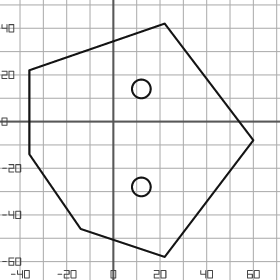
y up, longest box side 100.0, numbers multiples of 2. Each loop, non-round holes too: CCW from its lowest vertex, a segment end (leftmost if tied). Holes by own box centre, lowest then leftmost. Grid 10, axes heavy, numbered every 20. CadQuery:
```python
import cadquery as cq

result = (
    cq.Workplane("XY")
    .moveTo(22.0, -58.0)
    .lineTo(60.0, -8.0)
    .lineTo(22.0, 42.0)
    .lineTo(-36.0, 22.0)
    .lineTo(-36.0, -14.0)
    .lineTo(-14.0, -46.0)
    .close()
    .moveTo(12.0, -28.0)
    .circle(4.0)
    .moveTo(12.0, 14.0)
    .circle(4.0)
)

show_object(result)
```